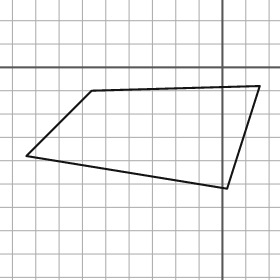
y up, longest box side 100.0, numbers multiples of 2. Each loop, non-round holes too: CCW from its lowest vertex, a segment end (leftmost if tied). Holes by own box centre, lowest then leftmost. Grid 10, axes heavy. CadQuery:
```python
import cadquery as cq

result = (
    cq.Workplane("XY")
    .moveTo(2.0, -52.0)
    .lineTo(16.0, -8.0)
    .lineTo(-56.0, -10.0)
    .lineTo(-84.0, -38.0)
    .close()
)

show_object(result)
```